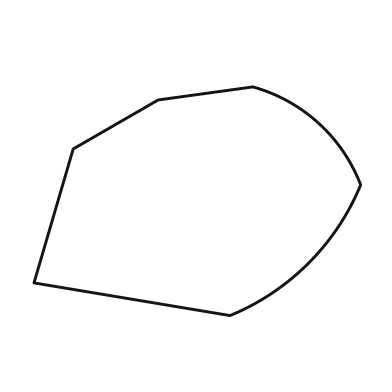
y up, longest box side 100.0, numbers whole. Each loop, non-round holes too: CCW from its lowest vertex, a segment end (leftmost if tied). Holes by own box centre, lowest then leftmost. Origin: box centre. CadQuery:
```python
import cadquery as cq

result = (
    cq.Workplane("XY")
    .moveTo(10.0, -35.0)
    .threePointArc((34.0, -19.0), (50.0, 5.0))
    .threePointArc((37.0, 24.0), (17.0, 35.0))
    .lineTo(-12.0, 31.0)
    .lineTo(-38.0, 16.0)
    .lineTo(-50.0, -25.0)
    .close()
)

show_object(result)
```